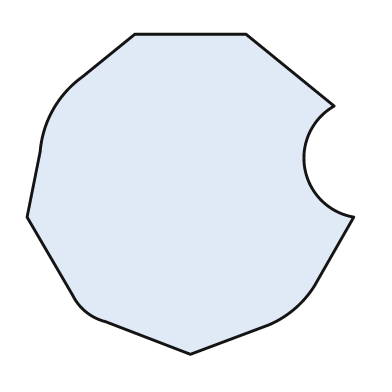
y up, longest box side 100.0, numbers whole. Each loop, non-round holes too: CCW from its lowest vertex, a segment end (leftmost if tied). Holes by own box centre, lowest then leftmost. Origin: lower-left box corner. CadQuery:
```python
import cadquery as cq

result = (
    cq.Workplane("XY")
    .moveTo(50.0, 0.0)
    .lineTo(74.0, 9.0)
    .threePointArc((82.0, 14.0), (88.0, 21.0))
    .lineTo(100.0, 42.0)
    .threePointArc((85.0, 57.0), (94.0, 76.0))
    .lineTo(67.0, 98.0)
    .lineTo(33.0, 98.0)
    .lineTo(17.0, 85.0)
    .threePointArc((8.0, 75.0), (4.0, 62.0))
    .lineTo(0.0, 42.0)
    .lineTo(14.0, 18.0)
    .threePointArc((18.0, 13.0), (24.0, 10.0))
    .close()
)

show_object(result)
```